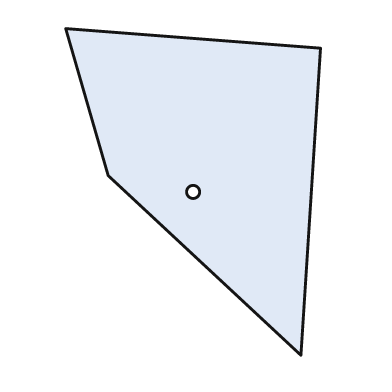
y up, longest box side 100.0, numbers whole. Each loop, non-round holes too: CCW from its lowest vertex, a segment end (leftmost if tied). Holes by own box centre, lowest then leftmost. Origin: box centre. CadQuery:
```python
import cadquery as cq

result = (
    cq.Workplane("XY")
    .moveTo(33.0, -50.0)
    .lineTo(39.0, 44.0)
    .lineTo(-39.0, 50.0)
    .lineTo(-26.0, 5.0)
    .close()
    .moveTo(0.0, 0.0)
    .circle(2.0)
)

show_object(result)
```